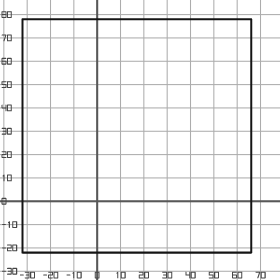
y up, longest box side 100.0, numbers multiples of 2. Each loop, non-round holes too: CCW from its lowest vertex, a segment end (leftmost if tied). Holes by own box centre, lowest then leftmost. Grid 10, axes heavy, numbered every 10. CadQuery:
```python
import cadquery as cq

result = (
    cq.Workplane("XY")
    .moveTo(-32.0, -22.0)
    .lineTo(66.0, -22.0)
    .lineTo(66.0, 78.0)
    .lineTo(-32.0, 78.0)
    .close()
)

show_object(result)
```